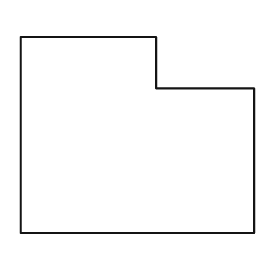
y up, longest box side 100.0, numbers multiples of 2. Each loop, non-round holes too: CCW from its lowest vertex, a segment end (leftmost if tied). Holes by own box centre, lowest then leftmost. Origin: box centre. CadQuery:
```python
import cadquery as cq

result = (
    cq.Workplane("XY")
    .moveTo(-50.0, -42.0)
    .lineTo(50.0, -42.0)
    .lineTo(50.0, 20.0)
    .lineTo(8.0, 20.0)
    .lineTo(8.0, 42.0)
    .lineTo(-50.0, 42.0)
    .close()
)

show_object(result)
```